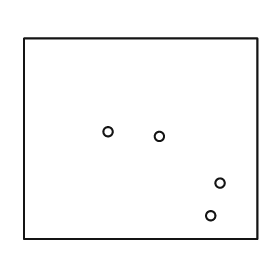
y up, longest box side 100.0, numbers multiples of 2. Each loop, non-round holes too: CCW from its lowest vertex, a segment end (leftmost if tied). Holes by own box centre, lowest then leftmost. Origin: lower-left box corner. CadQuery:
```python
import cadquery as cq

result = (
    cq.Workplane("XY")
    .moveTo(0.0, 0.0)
    .lineTo(100.0, 0.0)
    .lineTo(100.0, 86.0)
    .lineTo(0.0, 86.0)
    .close()
    .moveTo(80.0, 10.0)
    .circle(2.0)
    .moveTo(84.0, 24.0)
    .circle(2.0)
    .moveTo(58.0, 44.0)
    .circle(2.0)
    .moveTo(36.0, 46.0)
    .circle(2.0)
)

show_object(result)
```